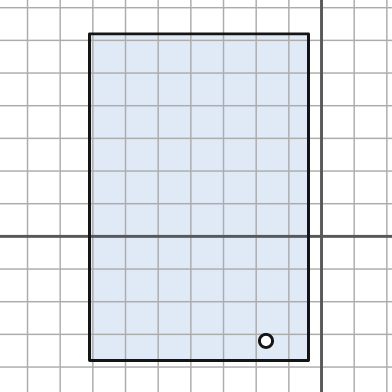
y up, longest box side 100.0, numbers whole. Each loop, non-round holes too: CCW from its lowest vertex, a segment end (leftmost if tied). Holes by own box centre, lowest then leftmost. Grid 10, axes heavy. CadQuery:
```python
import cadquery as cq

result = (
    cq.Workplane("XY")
    .moveTo(-71.0, -38.0)
    .lineTo(-4.0, -38.0)
    .lineTo(-4.0, 62.0)
    .lineTo(-71.0, 62.0)
    .close()
    .moveTo(-17.0, -32.0)
    .circle(2.0)
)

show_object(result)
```